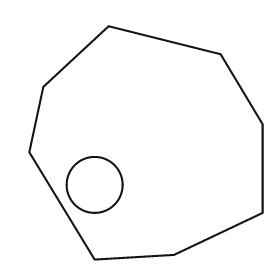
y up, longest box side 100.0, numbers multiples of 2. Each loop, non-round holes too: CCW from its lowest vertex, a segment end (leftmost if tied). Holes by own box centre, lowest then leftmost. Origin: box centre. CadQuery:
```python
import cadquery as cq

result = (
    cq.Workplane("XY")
    .moveTo(-22.0, -50.0)
    .lineTo(12.0, -48.0)
    .lineTo(50.0, -30.0)
    .lineTo(50.0, 8.0)
    .lineTo(32.0, 38.0)
    .lineTo(-16.0, 50.0)
    .lineTo(-44.0, 24.0)
    .lineTo(-50.0, -4.0)
    .close()
    .moveTo(-22.0, -18.0)
    .circle(12.0)
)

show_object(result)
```